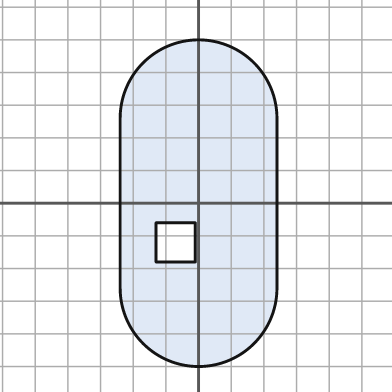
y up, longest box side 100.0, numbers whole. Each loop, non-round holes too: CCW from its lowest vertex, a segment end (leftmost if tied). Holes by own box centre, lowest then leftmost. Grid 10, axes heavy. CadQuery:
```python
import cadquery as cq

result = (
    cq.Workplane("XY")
    .moveTo(-24.0, -26.0)
    .threePointArc((0.0, -50.0), (24.0, -26.0))
    .lineTo(24.0, 26.0)
    .threePointArc((0.0, 50.0), (-24.0, 26.0))
    .close()
    .moveTo(-13.0, -18.0)
    .lineTo(-1.0, -18.0)
    .lineTo(-1.0, -6.0)
    .lineTo(-13.0, -6.0)
    .close()
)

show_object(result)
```